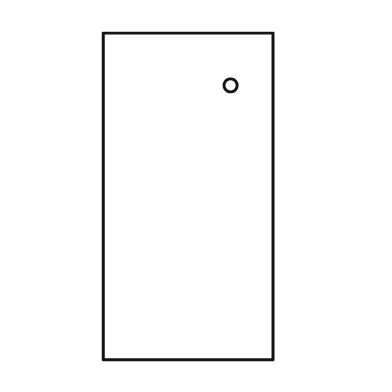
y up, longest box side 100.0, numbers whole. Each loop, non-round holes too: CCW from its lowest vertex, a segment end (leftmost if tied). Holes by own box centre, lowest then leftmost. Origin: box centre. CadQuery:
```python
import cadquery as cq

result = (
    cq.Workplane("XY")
    .moveTo(-26.0, -50.0)
    .lineTo(26.0, -50.0)
    .lineTo(26.0, 50.0)
    .lineTo(-26.0, 50.0)
    .close()
    .moveTo(13.0, 34.0)
    .circle(2.0)
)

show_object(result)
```